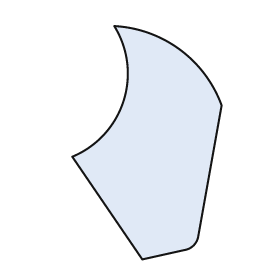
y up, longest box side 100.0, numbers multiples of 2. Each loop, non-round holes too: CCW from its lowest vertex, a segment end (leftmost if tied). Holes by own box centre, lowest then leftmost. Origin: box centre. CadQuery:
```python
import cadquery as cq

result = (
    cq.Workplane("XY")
    .moveTo(-2.0, -50.0)
    .lineTo(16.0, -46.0)
    .threePointArc((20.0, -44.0), (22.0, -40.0))
    .lineTo(32.0, 16.0)
    .threePointArc((14.0, 40.0), (-14.0, 50.0))
    .threePointArc((-10.0, 18.0), (-32.0, -6.0))
    .close()
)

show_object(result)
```